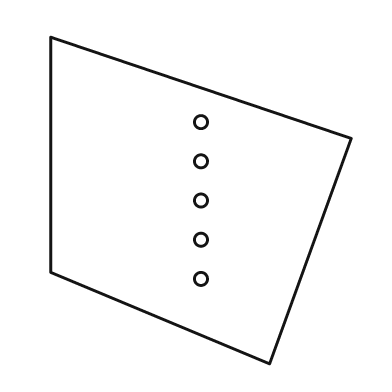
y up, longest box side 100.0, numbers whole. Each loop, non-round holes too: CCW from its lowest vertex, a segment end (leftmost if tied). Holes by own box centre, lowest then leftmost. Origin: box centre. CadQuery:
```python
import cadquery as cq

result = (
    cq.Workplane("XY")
    .moveTo(21.0, -50.0)
    .lineTo(46.0, 19.0)
    .lineTo(-46.0, 50.0)
    .lineTo(-46.0, -22.0)
    .close()
    .moveTo(0.0, -24.0)
    .circle(2.0)
    .moveTo(0.0, -12.0)
    .circle(2.0)
    .moveTo(0.0, 0.0)
    .circle(2.0)
    .moveTo(0.0, 12.0)
    .circle(2.0)
    .moveTo(0.0, 24.0)
    .circle(2.0)
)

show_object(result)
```